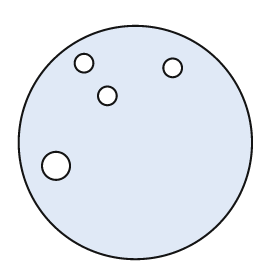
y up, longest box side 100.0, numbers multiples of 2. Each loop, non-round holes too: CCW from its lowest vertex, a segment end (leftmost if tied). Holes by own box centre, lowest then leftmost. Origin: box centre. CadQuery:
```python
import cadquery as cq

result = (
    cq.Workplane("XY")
    .moveTo(0.0, 0.0)
    .circle(50.0)
    .moveTo(-34.0, -10.0)
    .circle(6.0)
    .moveTo(-12.0, 20.0)
    .circle(4.0)
    .moveTo(16.0, 32.0)
    .circle(4.0)
    .moveTo(-22.0, 34.0)
    .circle(4.0)
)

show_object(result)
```